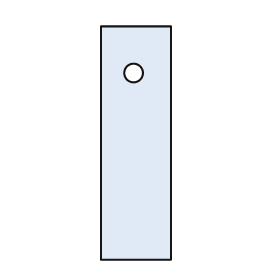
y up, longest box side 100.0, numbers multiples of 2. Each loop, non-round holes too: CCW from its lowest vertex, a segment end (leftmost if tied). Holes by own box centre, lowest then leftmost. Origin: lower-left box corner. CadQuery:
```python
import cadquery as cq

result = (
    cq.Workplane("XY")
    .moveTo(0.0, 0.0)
    .lineTo(30.0, 0.0)
    .lineTo(30.0, 100.0)
    .lineTo(0.0, 100.0)
    .close()
    .moveTo(14.0, 80.0)
    .circle(4.0)
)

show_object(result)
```